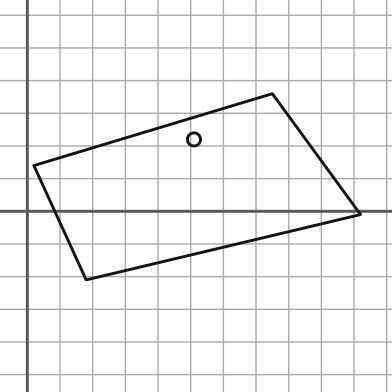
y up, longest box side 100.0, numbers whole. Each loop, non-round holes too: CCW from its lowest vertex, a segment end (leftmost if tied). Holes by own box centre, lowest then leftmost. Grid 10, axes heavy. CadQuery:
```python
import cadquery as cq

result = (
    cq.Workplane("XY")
    .moveTo(18.0, -21.0)
    .lineTo(102.0, -1.0)
    .lineTo(75.0, 36.0)
    .lineTo(2.0, 14.0)
    .close()
    .moveTo(51.0, 22.0)
    .circle(2.0)
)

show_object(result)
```